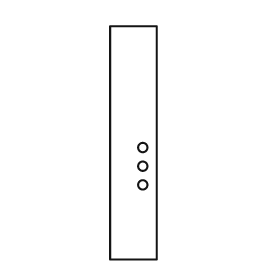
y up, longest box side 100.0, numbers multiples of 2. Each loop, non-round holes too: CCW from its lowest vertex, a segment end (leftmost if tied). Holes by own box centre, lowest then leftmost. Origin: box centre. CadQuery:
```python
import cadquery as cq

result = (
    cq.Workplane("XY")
    .moveTo(-10.0, -50.0)
    .lineTo(10.0, -50.0)
    .lineTo(10.0, 50.0)
    .lineTo(-10.0, 50.0)
    .close()
    .moveTo(4.0, -18.0)
    .circle(2.0)
    .moveTo(4.0, -10.0)
    .circle(2.0)
    .moveTo(4.0, -2.0)
    .circle(2.0)
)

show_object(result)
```